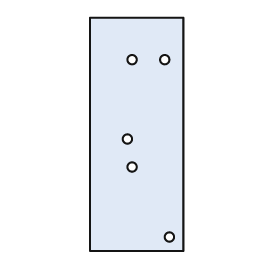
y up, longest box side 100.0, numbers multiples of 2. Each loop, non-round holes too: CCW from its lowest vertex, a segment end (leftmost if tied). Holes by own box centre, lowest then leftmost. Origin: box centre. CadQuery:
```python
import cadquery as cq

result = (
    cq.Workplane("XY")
    .moveTo(-20.0, -50.0)
    .lineTo(20.0, -50.0)
    .lineTo(20.0, 50.0)
    .lineTo(-20.0, 50.0)
    .close()
    .moveTo(14.0, -44.0)
    .circle(2.0)
    .moveTo(-2.0, -14.0)
    .circle(2.0)
    .moveTo(-4.0, -2.0)
    .circle(2.0)
    .moveTo(-2.0, 32.0)
    .circle(2.0)
    .moveTo(12.0, 32.0)
    .circle(2.0)
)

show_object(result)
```